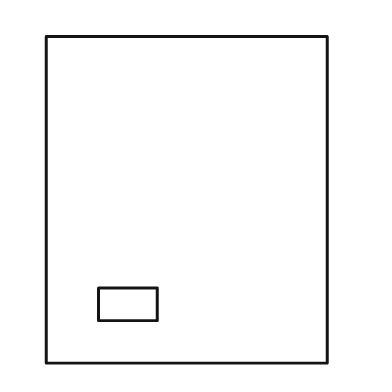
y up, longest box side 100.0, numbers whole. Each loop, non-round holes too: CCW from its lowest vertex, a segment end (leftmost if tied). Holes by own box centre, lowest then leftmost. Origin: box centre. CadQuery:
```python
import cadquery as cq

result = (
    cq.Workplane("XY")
    .moveTo(-43.0, -50.0)
    .lineTo(43.0, -50.0)
    .lineTo(43.0, 50.0)
    .lineTo(-43.0, 50.0)
    .close()
    .moveTo(-27.0, -37.0)
    .lineTo(-9.0, -37.0)
    .lineTo(-9.0, -27.0)
    .lineTo(-27.0, -27.0)
    .close()
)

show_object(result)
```